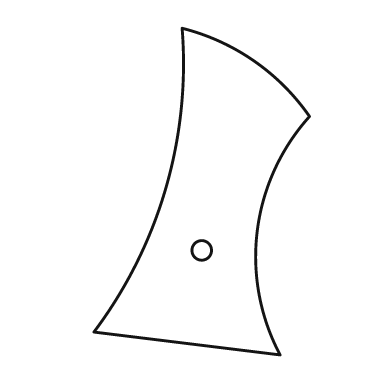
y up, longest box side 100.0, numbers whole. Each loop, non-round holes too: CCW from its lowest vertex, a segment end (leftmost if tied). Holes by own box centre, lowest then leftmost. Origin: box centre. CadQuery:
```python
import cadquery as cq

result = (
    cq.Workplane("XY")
    .moveTo(24.0, -50.0)
    .threePointArc((17.0, -12.0), (33.0, 23.0))
    .threePointArc((16.0, 40.0), (-6.0, 50.0))
    .threePointArc((-11.0, 1.0), (-33.0, -43.0))
    .close()
    .moveTo(0.0, -18.0)
    .circle(3.0)
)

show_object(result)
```